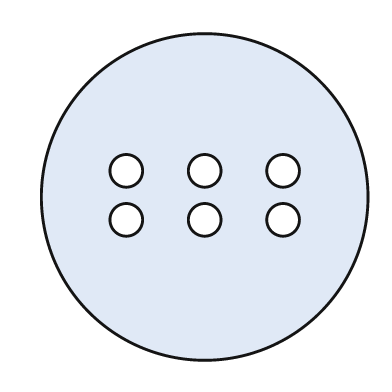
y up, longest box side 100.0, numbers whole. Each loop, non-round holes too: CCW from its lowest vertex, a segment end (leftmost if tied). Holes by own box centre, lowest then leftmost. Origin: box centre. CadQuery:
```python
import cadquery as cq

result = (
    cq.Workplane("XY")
    .moveTo(0.0, 0.0)
    .circle(50.0)
    .moveTo(-24.0, -7.0)
    .circle(5.0)
    .moveTo(0.0, -7.0)
    .circle(5.0)
    .moveTo(24.0, -7.0)
    .circle(5.0)
    .moveTo(-24.0, 8.0)
    .circle(5.0)
    .moveTo(0.0, 8.0)
    .circle(5.0)
    .moveTo(24.0, 8.0)
    .circle(5.0)
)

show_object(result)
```